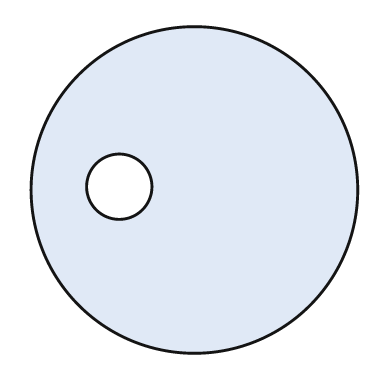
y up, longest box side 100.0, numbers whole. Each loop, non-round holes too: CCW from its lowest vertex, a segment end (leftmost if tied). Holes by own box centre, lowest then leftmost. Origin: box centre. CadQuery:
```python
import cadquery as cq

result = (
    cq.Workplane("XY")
    .moveTo(0.0, 0.0)
    .circle(50.0)
    .moveTo(-23.0, 1.0)
    .circle(10.0)
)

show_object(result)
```